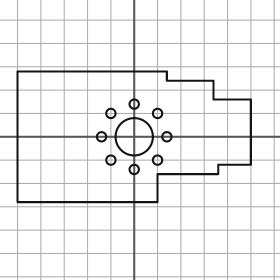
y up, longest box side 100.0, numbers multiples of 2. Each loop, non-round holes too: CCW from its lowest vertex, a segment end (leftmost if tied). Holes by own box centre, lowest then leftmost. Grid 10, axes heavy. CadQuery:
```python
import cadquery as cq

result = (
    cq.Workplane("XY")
    .moveTo(-50.0, -28.0)
    .lineTo(10.0, -28.0)
    .lineTo(10.0, -16.0)
    .lineTo(36.0, -16.0)
    .lineTo(36.0, -12.0)
    .lineTo(50.0, -12.0)
    .lineTo(50.0, 16.0)
    .lineTo(34.0, 16.0)
    .lineTo(34.0, 24.0)
    .lineTo(14.0, 24.0)
    .lineTo(14.0, 28.0)
    .lineTo(-50.0, 28.0)
    .close()
    .moveTo(0.0, -14.0)
    .circle(2.0)
    .moveTo(-10.0, -10.0)
    .circle(2.0)
    .moveTo(10.0, -10.0)
    .circle(2.0)
    .moveTo(-14.0, 0.0)
    .circle(2.0)
    .moveTo(0.0, 0.0)
    .circle(8.0)
    .moveTo(14.0, 0.0)
    .circle(2.0)
    .moveTo(-10.0, 10.0)
    .circle(2.0)
    .moveTo(10.0, 10.0)
    .circle(2.0)
    .moveTo(0.0, 14.0)
    .circle(2.0)
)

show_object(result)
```